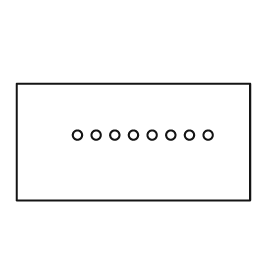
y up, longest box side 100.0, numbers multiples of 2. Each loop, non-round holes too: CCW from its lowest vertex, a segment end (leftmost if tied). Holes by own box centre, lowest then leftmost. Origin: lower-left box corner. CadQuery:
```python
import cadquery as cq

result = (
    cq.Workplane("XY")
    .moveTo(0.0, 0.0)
    .lineTo(100.0, 0.0)
    .lineTo(100.0, 50.0)
    .lineTo(0.0, 50.0)
    .close()
    .moveTo(26.0, 28.0)
    .circle(2.0)
    .moveTo(34.0, 28.0)
    .circle(2.0)
    .moveTo(42.0, 28.0)
    .circle(2.0)
    .moveTo(50.0, 28.0)
    .circle(2.0)
    .moveTo(58.0, 28.0)
    .circle(2.0)
    .moveTo(66.0, 28.0)
    .circle(2.0)
    .moveTo(74.0, 28.0)
    .circle(2.0)
    .moveTo(82.0, 28.0)
    .circle(2.0)
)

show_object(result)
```